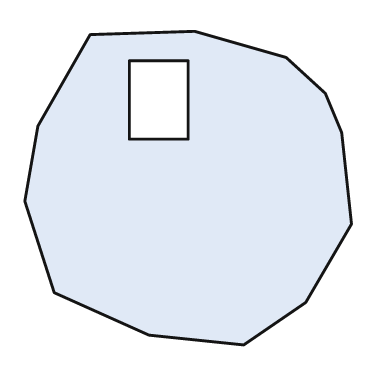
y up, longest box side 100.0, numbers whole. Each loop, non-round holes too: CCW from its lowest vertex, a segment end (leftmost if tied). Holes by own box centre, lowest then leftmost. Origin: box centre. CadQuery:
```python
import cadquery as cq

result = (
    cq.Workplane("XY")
    .moveTo(17.0, -48.0)
    .lineTo(36.0, -35.0)
    .lineTo(50.0, -11.0)
    .lineTo(47.0, 17.0)
    .lineTo(42.0, 29.0)
    .lineTo(30.0, 40.0)
    .lineTo(2.0, 48.0)
    .lineTo(-30.0, 47.0)
    .lineTo(-46.0, 19.0)
    .lineTo(-50.0, -4.0)
    .lineTo(-41.0, -32.0)
    .lineTo(-12.0, -45.0)
    .close()
    .moveTo(-18.0, 15.0)
    .lineTo(0.0, 15.0)
    .lineTo(0.0, 39.0)
    .lineTo(-18.0, 39.0)
    .close()
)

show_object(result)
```